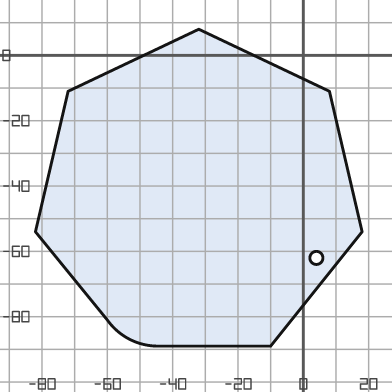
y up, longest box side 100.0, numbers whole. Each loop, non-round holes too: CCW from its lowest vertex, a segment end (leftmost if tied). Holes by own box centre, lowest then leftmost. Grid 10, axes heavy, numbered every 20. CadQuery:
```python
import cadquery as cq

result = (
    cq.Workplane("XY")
    .moveTo(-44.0, -89.0)
    .lineTo(-10.0, -89.0)
    .lineTo(18.0, -54.0)
    .lineTo(8.0, -11.0)
    .lineTo(-32.0, 8.0)
    .lineTo(-72.0, -11.0)
    .lineTo(-82.0, -54.0)
    .lineTo(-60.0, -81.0)
    .threePointArc((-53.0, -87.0), (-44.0, -89.0))
    .close()
    .moveTo(4.0, -62.0)
    .circle(2.0)
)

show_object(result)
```